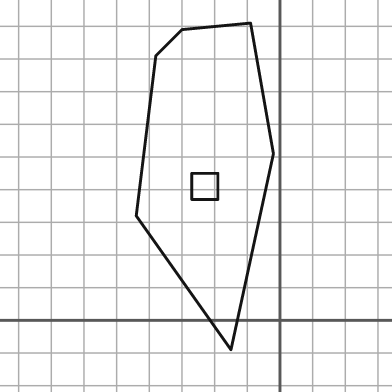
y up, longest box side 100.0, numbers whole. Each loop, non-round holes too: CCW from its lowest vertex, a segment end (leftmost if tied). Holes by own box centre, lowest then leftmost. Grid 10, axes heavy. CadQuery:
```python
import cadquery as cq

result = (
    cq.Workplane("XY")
    .moveTo(-15.0, -9.0)
    .lineTo(-2.0, 51.0)
    .lineTo(-9.0, 91.0)
    .lineTo(-30.0, 89.0)
    .lineTo(-38.0, 81.0)
    .lineTo(-44.0, 32.0)
    .close()
    .moveTo(-27.0, 37.0)
    .lineTo(-19.0, 37.0)
    .lineTo(-19.0, 45.0)
    .lineTo(-27.0, 45.0)
    .close()
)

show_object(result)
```